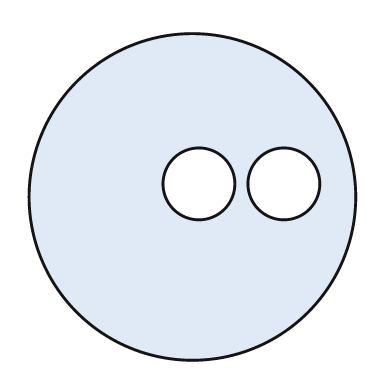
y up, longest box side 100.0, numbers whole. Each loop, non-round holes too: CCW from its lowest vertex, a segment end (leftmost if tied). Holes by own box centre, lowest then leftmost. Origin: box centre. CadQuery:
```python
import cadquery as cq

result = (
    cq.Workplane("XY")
    .moveTo(0.0, 0.0)
    .circle(50.0)
    .moveTo(2.0, 4.0)
    .circle(11.0)
    .moveTo(28.0, 4.0)
    .circle(11.0)
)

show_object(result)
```